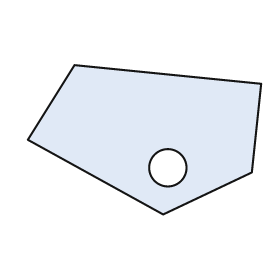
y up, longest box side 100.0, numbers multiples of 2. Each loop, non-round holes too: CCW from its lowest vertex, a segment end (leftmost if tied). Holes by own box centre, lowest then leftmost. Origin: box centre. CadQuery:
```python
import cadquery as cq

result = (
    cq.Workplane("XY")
    .moveTo(8.0, -32.0)
    .lineTo(46.0, -14.0)
    .lineTo(50.0, 24.0)
    .lineTo(-30.0, 32.0)
    .lineTo(-50.0, 0.0)
    .close()
    .moveTo(10.0, -12.0)
    .circle(8.0)
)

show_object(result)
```